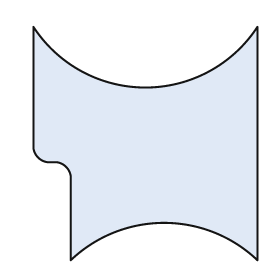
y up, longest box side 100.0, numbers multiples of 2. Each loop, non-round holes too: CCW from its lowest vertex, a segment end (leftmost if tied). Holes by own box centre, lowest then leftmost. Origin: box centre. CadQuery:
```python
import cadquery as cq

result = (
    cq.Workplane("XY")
    .moveTo(-32.0, -50.0)
    .threePointArc((8.0, -34.0), (48.0, -50.0))
    .lineTo(48.0, 50.0)
    .threePointArc((0.0, 24.0), (-48.0, 50.0))
    .lineTo(-48.0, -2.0)
    .threePointArc((-46.0, -6.0), (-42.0, -8.0))
    .lineTo(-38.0, -8.0)
    .threePointArc((-34.0, -10.0), (-32.0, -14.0))
    .close()
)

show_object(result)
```